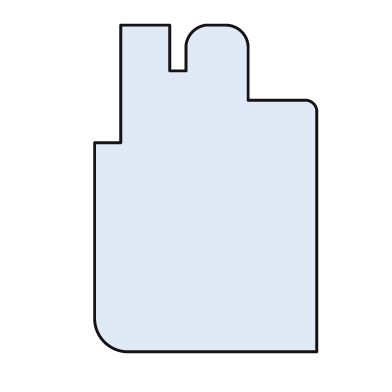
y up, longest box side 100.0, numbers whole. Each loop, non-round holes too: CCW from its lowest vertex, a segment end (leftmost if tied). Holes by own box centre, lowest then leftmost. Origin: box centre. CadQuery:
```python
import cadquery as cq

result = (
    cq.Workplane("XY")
    .moveTo(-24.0, -50.0)
    .lineTo(34.0, -50.0)
    .lineTo(34.0, 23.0)
    .threePointArc((33.0, 26.0), (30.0, 27.0))
    .lineTo(13.0, 27.0)
    .lineTo(13.0, 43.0)
    .threePointArc((11.0, 48.0), (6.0, 50.0))
    .lineTo(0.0, 50.0)
    .threePointArc((-4.0, 48.0), (-6.0, 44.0))
    .lineTo(-6.0, 36.0)
    .lineTo(-11.0, 36.0)
    .lineTo(-11.0, 50.0)
    .lineTo(-26.0, 50.0)
    .lineTo(-26.0, 14.0)
    .lineTo(-34.0, 14.0)
    .lineTo(-34.0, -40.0)
    .threePointArc((-31.0, -47.0), (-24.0, -50.0))
    .close()
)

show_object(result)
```